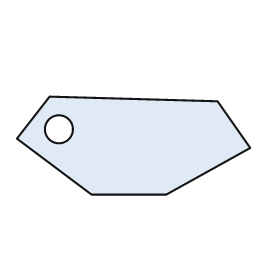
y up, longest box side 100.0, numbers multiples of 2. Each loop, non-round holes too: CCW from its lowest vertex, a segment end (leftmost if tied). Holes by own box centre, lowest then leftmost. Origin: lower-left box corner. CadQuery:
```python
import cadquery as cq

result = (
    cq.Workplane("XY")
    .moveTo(32.0, 0.0)
    .lineTo(64.0, 0.0)
    .lineTo(100.0, 20.0)
    .lineTo(86.0, 40.0)
    .lineTo(14.0, 42.0)
    .lineTo(0.0, 24.0)
    .close()
    .moveTo(18.0, 28.0)
    .circle(6.0)
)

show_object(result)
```